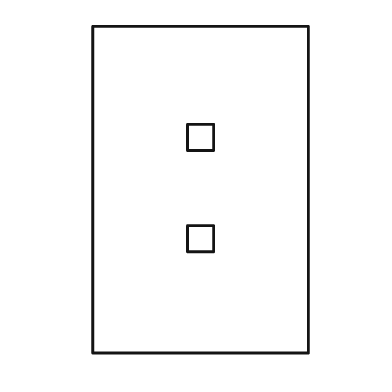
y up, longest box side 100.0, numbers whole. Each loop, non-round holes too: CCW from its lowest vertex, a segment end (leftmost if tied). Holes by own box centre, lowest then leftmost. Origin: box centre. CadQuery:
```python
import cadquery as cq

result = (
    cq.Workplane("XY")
    .moveTo(-33.0, -50.0)
    .lineTo(33.0, -50.0)
    .lineTo(33.0, 50.0)
    .lineTo(-33.0, 50.0)
    .close()
    .moveTo(-4.0, -19.0)
    .lineTo(4.0, -19.0)
    .lineTo(4.0, -11.0)
    .lineTo(-4.0, -11.0)
    .close()
    .moveTo(-4.0, 12.0)
    .lineTo(4.0, 12.0)
    .lineTo(4.0, 20.0)
    .lineTo(-4.0, 20.0)
    .close()
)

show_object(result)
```